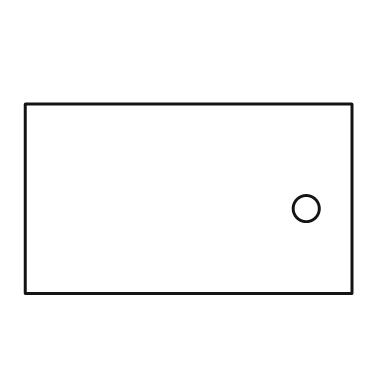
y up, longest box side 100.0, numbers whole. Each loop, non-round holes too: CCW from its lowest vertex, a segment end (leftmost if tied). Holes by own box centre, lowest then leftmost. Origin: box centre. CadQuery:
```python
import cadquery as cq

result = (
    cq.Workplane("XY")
    .moveTo(-50.0, -29.0)
    .lineTo(50.0, -29.0)
    .lineTo(50.0, 29.0)
    .lineTo(-50.0, 29.0)
    .close()
    .moveTo(36.0, -3.0)
    .circle(4.0)
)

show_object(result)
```